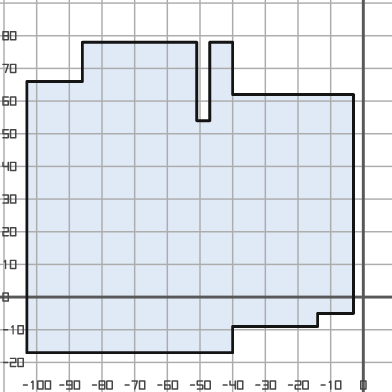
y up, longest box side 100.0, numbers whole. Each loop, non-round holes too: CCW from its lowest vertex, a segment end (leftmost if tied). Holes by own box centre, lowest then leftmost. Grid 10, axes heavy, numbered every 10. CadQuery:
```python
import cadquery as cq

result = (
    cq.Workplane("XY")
    .moveTo(-103.0, -17.0)
    .lineTo(-40.0, -17.0)
    .lineTo(-40.0, -9.0)
    .lineTo(-14.0, -9.0)
    .lineTo(-14.0, -5.0)
    .lineTo(-3.0, -5.0)
    .lineTo(-3.0, 62.0)
    .lineTo(-40.0, 62.0)
    .lineTo(-40.0, 78.0)
    .lineTo(-47.0, 78.0)
    .lineTo(-47.0, 54.0)
    .lineTo(-51.0, 54.0)
    .lineTo(-51.0, 78.0)
    .lineTo(-86.0, 78.0)
    .lineTo(-86.0, 66.0)
    .lineTo(-103.0, 66.0)
    .close()
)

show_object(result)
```